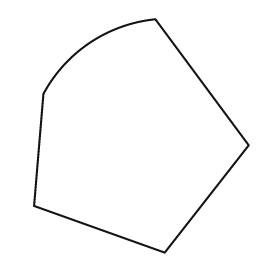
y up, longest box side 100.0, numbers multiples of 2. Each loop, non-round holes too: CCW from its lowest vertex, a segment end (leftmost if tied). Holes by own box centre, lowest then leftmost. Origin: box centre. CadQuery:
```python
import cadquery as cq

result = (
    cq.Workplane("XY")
    .moveTo(10.0, -50.0)
    .lineTo(46.0, -4.0)
    .lineTo(6.0, 50.0)
    .threePointArc((-22.0, 40.0), (-42.0, 18.0))
    .lineTo(-46.0, -30.0)
    .close()
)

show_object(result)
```